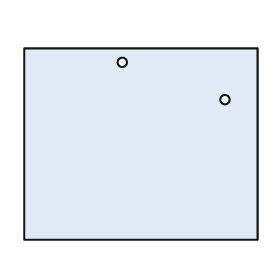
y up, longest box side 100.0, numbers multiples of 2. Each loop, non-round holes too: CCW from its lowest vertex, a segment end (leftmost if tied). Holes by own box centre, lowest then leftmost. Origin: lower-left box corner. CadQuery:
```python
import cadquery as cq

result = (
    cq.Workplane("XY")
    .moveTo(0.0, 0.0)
    .lineTo(100.0, 0.0)
    .lineTo(100.0, 82.0)
    .lineTo(0.0, 82.0)
    .close()
    .moveTo(86.0, 60.0)
    .circle(2.0)
    .moveTo(42.0, 76.0)
    .circle(2.0)
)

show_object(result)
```